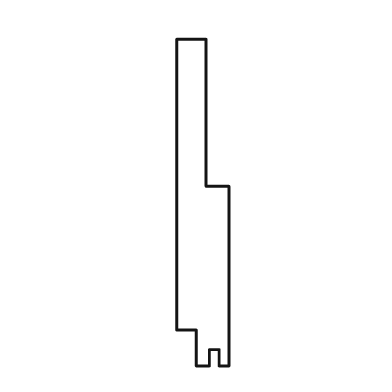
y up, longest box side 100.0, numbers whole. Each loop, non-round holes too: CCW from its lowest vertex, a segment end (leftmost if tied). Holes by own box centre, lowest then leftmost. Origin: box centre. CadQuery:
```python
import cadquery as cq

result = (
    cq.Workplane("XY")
    .moveTo(-2.0, -50.0)
    .lineTo(2.0, -50.0)
    .lineTo(2.0, -45.0)
    .lineTo(5.0, -45.0)
    .lineTo(5.0, -50.0)
    .lineTo(8.0, -50.0)
    .lineTo(8.0, 5.0)
    .lineTo(1.0, 5.0)
    .lineTo(1.0, 50.0)
    .lineTo(-8.0, 50.0)
    .lineTo(-8.0, -39.0)
    .lineTo(-2.0, -39.0)
    .close()
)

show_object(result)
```